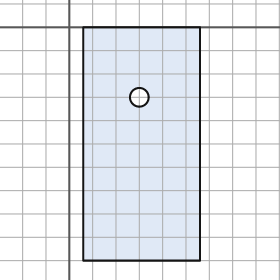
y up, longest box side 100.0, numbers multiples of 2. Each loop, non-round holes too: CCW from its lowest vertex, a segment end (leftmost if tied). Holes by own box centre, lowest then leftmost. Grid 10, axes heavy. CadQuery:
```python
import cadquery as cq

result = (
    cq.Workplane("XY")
    .moveTo(6.0, -100.0)
    .lineTo(56.0, -100.0)
    .lineTo(56.0, 0.0)
    .lineTo(6.0, 0.0)
    .close()
    .moveTo(30.0, -30.0)
    .circle(4.0)
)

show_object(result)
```